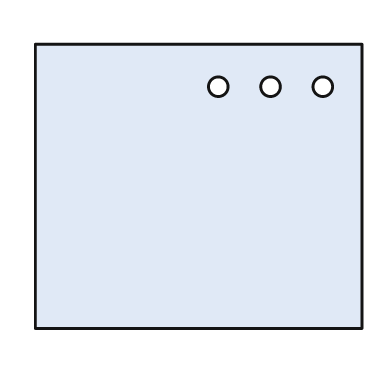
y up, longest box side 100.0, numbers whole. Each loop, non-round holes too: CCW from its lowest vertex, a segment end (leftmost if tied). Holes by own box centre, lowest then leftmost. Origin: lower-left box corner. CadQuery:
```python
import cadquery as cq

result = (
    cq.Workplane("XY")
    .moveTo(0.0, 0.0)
    .lineTo(100.0, 0.0)
    .lineTo(100.0, 87.0)
    .lineTo(0.0, 87.0)
    .close()
    .moveTo(56.0, 74.0)
    .circle(3.0)
    .moveTo(72.0, 74.0)
    .circle(3.0)
    .moveTo(88.0, 74.0)
    .circle(3.0)
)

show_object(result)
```